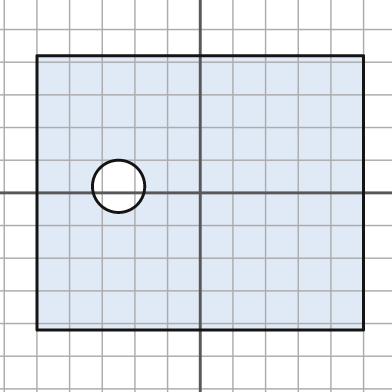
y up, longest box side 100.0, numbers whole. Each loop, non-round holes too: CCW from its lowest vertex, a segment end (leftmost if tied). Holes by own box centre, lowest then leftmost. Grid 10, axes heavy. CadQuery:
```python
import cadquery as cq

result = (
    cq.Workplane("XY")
    .moveTo(-50.0, -42.0)
    .lineTo(50.0, -42.0)
    .lineTo(50.0, 42.0)
    .lineTo(-50.0, 42.0)
    .close()
    .moveTo(-25.0, 2.0)
    .circle(8.0)
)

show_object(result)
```